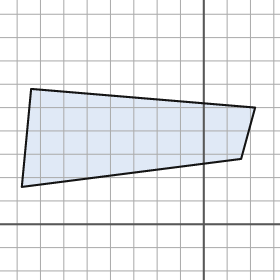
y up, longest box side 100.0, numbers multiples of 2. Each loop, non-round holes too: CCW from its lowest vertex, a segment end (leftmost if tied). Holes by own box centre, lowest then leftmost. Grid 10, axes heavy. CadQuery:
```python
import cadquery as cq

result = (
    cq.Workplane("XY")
    .moveTo(-78.0, 16.0)
    .lineTo(16.0, 28.0)
    .lineTo(22.0, 50.0)
    .lineTo(-74.0, 58.0)
    .close()
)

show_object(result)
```